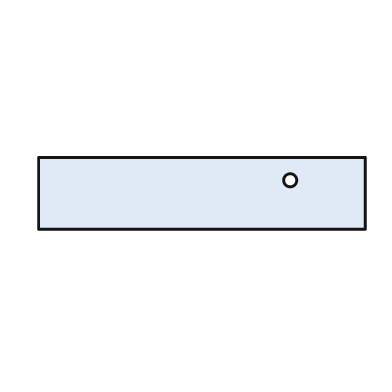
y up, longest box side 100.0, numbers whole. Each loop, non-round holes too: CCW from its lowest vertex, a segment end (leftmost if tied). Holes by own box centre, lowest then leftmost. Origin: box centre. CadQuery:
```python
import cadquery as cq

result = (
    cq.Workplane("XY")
    .moveTo(-50.0, -11.0)
    .lineTo(50.0, -11.0)
    .lineTo(50.0, 11.0)
    .lineTo(-50.0, 11.0)
    .close()
    .moveTo(27.0, 4.0)
    .circle(2.0)
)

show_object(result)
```